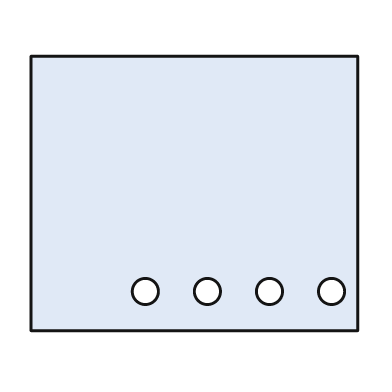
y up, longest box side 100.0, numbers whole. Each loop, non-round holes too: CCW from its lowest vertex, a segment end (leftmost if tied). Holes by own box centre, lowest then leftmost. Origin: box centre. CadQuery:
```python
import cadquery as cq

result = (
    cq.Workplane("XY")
    .moveTo(-50.0, -42.0)
    .lineTo(50.0, -42.0)
    .lineTo(50.0, 42.0)
    .lineTo(-50.0, 42.0)
    .close()
    .moveTo(-15.0, -30.0)
    .circle(4.0)
    .moveTo(4.0, -30.0)
    .circle(4.0)
    .moveTo(23.0, -30.0)
    .circle(4.0)
    .moveTo(42.0, -30.0)
    .circle(4.0)
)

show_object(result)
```